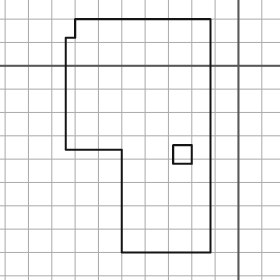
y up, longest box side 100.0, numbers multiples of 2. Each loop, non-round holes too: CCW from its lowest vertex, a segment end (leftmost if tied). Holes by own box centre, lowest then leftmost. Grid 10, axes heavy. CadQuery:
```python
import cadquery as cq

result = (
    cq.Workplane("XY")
    .moveTo(-50.0, -80.0)
    .lineTo(-12.0, -80.0)
    .lineTo(-12.0, 20.0)
    .lineTo(-70.0, 20.0)
    .lineTo(-70.0, 12.0)
    .lineTo(-74.0, 12.0)
    .lineTo(-74.0, -36.0)
    .lineTo(-50.0, -36.0)
    .close()
    .moveTo(-28.0, -42.0)
    .lineTo(-20.0, -42.0)
    .lineTo(-20.0, -34.0)
    .lineTo(-28.0, -34.0)
    .close()
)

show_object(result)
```